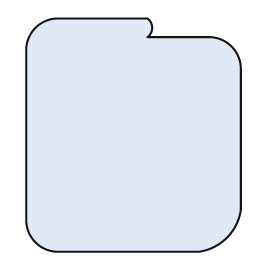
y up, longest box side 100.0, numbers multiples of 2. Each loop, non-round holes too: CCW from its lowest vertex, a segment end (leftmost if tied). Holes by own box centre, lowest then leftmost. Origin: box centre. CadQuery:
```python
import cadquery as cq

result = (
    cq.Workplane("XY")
    .moveTo(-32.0, -50.0)
    .lineTo(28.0, -50.0)
    .threePointArc((40.0, -44.0), (46.0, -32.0))
    .lineTo(46.0, 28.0)
    .threePointArc((42.0, 38.0), (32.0, 42.0))
    .lineTo(6.0, 42.0)
    .threePointArc((8.0, 46.0), (6.0, 50.0))
    .lineTo(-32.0, 50.0)
    .threePointArc((-42.0, 46.0), (-46.0, 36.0))
    .lineTo(-46.0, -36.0)
    .threePointArc((-42.0, -46.0), (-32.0, -50.0))
    .close()
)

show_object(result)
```